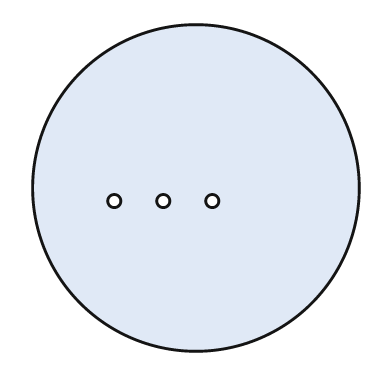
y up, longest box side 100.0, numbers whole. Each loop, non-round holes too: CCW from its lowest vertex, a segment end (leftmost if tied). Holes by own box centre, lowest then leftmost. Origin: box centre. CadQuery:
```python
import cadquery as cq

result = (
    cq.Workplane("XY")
    .moveTo(0.0, 0.0)
    .circle(50.0)
    .moveTo(-25.0, -4.0)
    .circle(2.0)
    .moveTo(-10.0, -4.0)
    .circle(2.0)
    .moveTo(5.0, -4.0)
    .circle(2.0)
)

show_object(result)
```